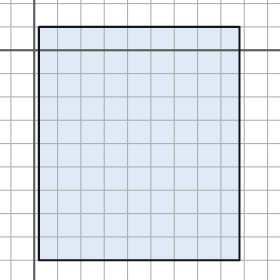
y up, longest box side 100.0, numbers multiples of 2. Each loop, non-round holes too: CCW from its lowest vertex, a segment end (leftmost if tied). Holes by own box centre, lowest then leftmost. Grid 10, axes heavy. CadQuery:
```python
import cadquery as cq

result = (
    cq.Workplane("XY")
    .moveTo(2.0, -90.0)
    .lineTo(88.0, -90.0)
    .lineTo(88.0, 10.0)
    .lineTo(2.0, 10.0)
    .close()
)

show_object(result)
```